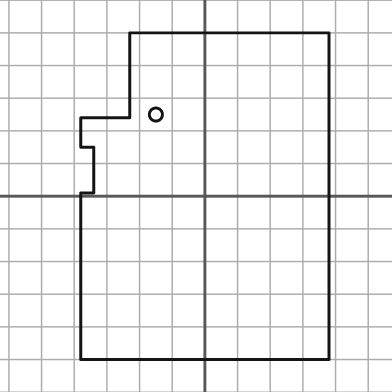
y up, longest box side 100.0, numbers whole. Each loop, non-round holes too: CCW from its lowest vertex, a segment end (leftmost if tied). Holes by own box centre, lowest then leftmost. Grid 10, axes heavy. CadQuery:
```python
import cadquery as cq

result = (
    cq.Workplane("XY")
    .moveTo(-38.0, -50.0)
    .lineTo(38.0, -50.0)
    .lineTo(38.0, 50.0)
    .lineTo(-23.0, 50.0)
    .lineTo(-23.0, 24.0)
    .lineTo(-38.0, 24.0)
    .lineTo(-38.0, 15.0)
    .lineTo(-34.0, 15.0)
    .lineTo(-34.0, 1.0)
    .lineTo(-38.0, 1.0)
    .close()
    .moveTo(-15.0, 25.0)
    .circle(2.0)
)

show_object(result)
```